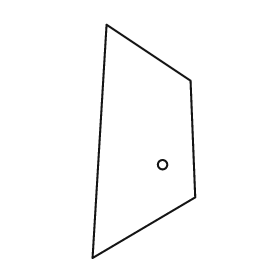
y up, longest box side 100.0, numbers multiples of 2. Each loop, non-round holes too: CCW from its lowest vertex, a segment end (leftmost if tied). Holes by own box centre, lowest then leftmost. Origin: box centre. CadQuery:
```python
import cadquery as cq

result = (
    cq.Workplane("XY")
    .moveTo(-22.0, -50.0)
    .lineTo(22.0, -24.0)
    .lineTo(20.0, 26.0)
    .lineTo(-16.0, 50.0)
    .close()
    .moveTo(8.0, -10.0)
    .circle(2.0)
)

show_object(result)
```